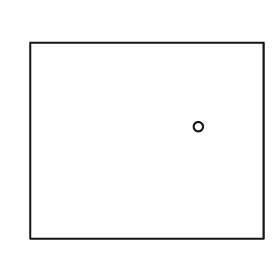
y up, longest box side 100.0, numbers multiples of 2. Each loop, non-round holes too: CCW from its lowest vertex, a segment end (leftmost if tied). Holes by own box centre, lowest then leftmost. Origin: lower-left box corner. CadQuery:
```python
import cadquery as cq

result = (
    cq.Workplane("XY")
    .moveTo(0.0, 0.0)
    .lineTo(100.0, 0.0)
    .lineTo(100.0, 84.0)
    .lineTo(0.0, 84.0)
    .close()
    .moveTo(72.0, 48.0)
    .circle(2.0)
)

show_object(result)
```